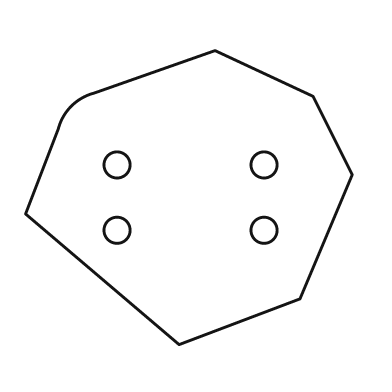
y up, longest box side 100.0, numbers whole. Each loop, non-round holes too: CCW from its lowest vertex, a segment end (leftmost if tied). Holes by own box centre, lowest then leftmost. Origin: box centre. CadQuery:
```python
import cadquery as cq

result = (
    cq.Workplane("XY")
    .moveTo(-3.0, -45.0)
    .lineTo(34.0, -31.0)
    .lineTo(50.0, 7.0)
    .lineTo(38.0, 31.0)
    .lineTo(8.0, 45.0)
    .lineTo(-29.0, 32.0)
    .threePointArc((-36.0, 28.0), (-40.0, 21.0))
    .lineTo(-50.0, -5.0)
    .close()
    .moveTo(-22.0, -10.0)
    .circle(4.0)
    .moveTo(23.0, -10.0)
    .circle(4.0)
    .moveTo(-22.0, 10.0)
    .circle(4.0)
    .moveTo(23.0, 10.0)
    .circle(4.0)
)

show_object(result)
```